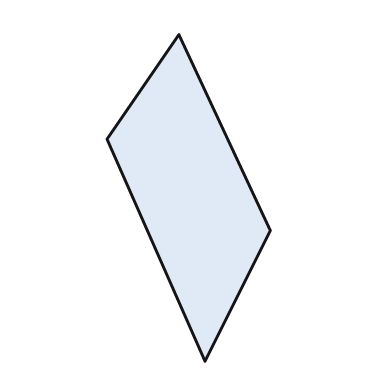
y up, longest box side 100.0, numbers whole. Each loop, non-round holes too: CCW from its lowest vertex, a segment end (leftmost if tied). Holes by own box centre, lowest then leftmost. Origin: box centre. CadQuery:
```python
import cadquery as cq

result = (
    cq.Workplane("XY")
    .moveTo(5.0, -50.0)
    .lineTo(25.0, -10.0)
    .lineTo(-3.0, 50.0)
    .lineTo(-25.0, 18.0)
    .close()
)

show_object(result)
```